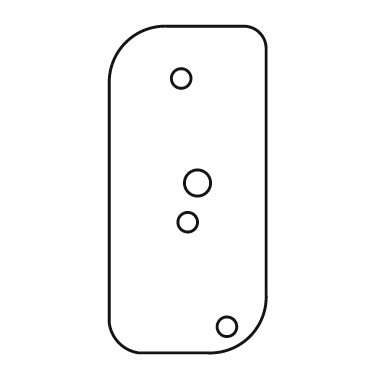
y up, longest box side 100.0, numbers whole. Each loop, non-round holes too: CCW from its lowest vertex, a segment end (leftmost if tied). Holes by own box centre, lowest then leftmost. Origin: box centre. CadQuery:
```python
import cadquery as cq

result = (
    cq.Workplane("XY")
    .moveTo(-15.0, -50.0)
    .lineTo(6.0, -50.0)
    .threePointArc((19.0, -45.0), (24.0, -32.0))
    .lineTo(24.0, 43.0)
    .threePointArc((22.0, 48.0), (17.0, 50.0))
    .lineTo(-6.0, 50.0)
    .threePointArc((-19.0, 45.0), (-24.0, 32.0))
    .lineTo(-24.0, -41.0)
    .threePointArc((-21.0, -47.0), (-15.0, -50.0))
    .close()
    .moveTo(12.0, -42.0)
    .circle(3.0)
    .moveTo(0.0, -10.0)
    .circle(3.0)
    .moveTo(3.0, 2.0)
    .circle(4.0)
    .moveTo(-2.0, 34.0)
    .circle(3.0)
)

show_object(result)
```